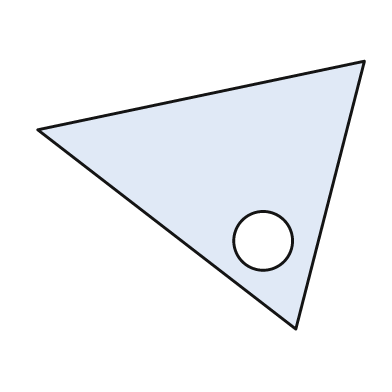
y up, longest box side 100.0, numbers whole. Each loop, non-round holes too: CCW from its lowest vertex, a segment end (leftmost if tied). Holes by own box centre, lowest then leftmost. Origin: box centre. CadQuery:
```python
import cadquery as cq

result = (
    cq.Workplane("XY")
    .moveTo(29.0, -41.0)
    .lineTo(50.0, 41.0)
    .lineTo(-50.0, 20.0)
    .close()
    .moveTo(19.0, -14.0)
    .circle(9.0)
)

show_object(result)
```